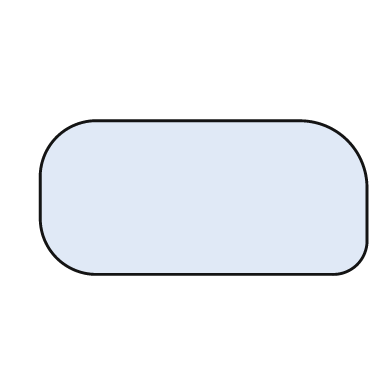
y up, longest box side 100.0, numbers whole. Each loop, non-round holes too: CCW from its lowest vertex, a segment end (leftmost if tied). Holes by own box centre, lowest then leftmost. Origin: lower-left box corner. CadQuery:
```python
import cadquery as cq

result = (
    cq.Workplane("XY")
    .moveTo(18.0, 0.0)
    .lineTo(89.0, 0.0)
    .threePointArc((97.0, 3.0), (100.0, 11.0))
    .lineTo(100.0, 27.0)
    .threePointArc((94.0, 41.0), (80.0, 47.0))
    .lineTo(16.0, 47.0)
    .threePointArc((5.0, 42.0), (0.0, 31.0))
    .lineTo(0.0, 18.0)
    .threePointArc((5.0, 5.0), (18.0, 0.0))
    .close()
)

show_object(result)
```